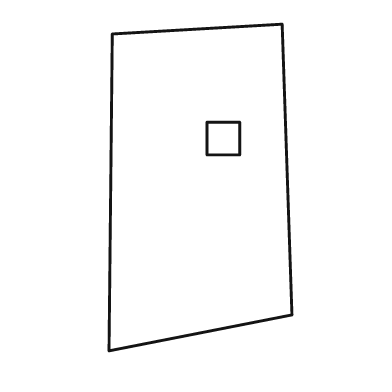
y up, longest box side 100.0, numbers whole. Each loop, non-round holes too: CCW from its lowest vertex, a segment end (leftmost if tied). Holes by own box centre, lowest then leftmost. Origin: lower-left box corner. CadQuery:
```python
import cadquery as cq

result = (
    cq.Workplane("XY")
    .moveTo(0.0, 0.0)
    .lineTo(56.0, 11.0)
    .lineTo(53.0, 100.0)
    .lineTo(1.0, 97.0)
    .close()
    .moveTo(30.0, 60.0)
    .lineTo(40.0, 60.0)
    .lineTo(40.0, 70.0)
    .lineTo(30.0, 70.0)
    .close()
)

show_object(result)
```